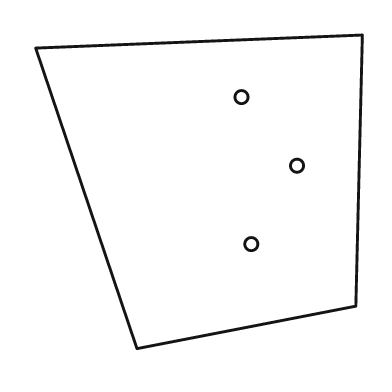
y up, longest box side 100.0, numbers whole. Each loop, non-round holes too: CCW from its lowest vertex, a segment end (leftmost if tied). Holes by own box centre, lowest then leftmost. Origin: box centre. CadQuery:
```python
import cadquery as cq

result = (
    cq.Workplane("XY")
    .moveTo(-19.0, -48.0)
    .lineTo(48.0, -35.0)
    .lineTo(50.0, 48.0)
    .lineTo(-50.0, 44.0)
    .close()
    .moveTo(16.0, -16.0)
    .circle(2.0)
    .moveTo(30.0, 8.0)
    .circle(2.0)
    .moveTo(13.0, 29.0)
    .circle(2.0)
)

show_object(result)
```